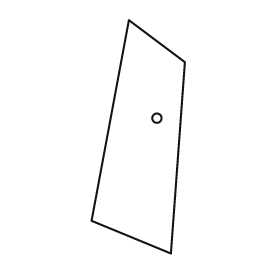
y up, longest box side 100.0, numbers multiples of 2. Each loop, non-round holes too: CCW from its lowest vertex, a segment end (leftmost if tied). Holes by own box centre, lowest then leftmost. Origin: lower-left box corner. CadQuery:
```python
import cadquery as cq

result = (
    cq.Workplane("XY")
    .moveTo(34.0, 0.0)
    .lineTo(40.0, 82.0)
    .lineTo(16.0, 100.0)
    .lineTo(0.0, 14.0)
    .close()
    .moveTo(28.0, 58.0)
    .circle(2.0)
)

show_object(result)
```